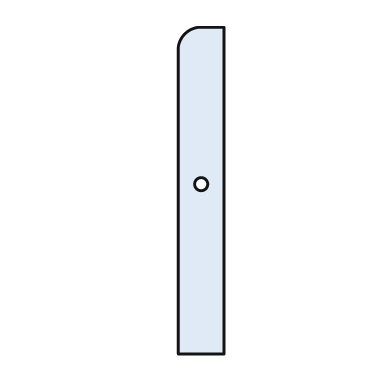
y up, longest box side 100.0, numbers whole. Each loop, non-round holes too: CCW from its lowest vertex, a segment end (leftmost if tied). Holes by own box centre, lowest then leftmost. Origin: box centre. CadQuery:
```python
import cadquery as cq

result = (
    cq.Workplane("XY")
    .moveTo(-7.0, -50.0)
    .lineTo(7.0, -50.0)
    .lineTo(7.0, 50.0)
    .lineTo(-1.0, 50.0)
    .threePointArc((-5.0, 48.0), (-7.0, 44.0))
    .close()
    .moveTo(0.0, 2.0)
    .circle(2.0)
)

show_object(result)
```